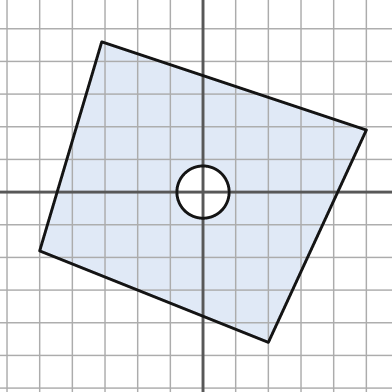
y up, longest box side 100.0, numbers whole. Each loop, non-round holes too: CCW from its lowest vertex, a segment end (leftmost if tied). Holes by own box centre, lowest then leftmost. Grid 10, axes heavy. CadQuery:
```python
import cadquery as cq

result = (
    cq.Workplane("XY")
    .moveTo(20.0, -46.0)
    .lineTo(50.0, 19.0)
    .lineTo(-31.0, 46.0)
    .lineTo(-50.0, -18.0)
    .close()
    .moveTo(0.0, 0.0)
    .circle(8.0)
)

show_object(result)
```